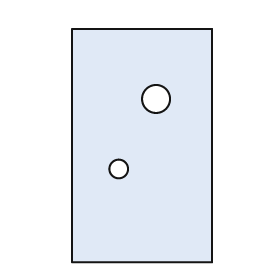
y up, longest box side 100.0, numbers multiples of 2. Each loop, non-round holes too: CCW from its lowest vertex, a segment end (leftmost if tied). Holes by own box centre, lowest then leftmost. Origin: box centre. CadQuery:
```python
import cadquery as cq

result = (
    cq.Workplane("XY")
    .moveTo(-30.0, -50.0)
    .lineTo(30.0, -50.0)
    .lineTo(30.0, 50.0)
    .lineTo(-30.0, 50.0)
    .close()
    .moveTo(-10.0, -10.0)
    .circle(4.0)
    .moveTo(6.0, 20.0)
    .circle(6.0)
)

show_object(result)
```